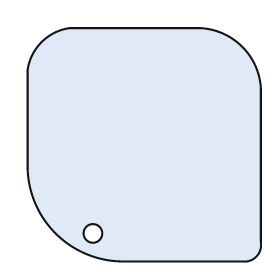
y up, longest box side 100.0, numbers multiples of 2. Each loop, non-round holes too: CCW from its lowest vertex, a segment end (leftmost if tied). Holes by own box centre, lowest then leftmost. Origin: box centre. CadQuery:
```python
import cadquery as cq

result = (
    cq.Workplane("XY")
    .moveTo(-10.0, -50.0)
    .lineTo(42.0, -50.0)
    .threePointArc((48.0, -48.0), (50.0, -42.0))
    .lineTo(50.0, 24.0)
    .threePointArc((42.0, 42.0), (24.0, 50.0))
    .lineTo(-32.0, 50.0)
    .threePointArc((-44.0, 44.0), (-50.0, 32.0))
    .lineTo(-50.0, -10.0)
    .threePointArc((-38.0, -38.0), (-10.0, -50.0))
    .close()
    .moveTo(-22.0, -38.0)
    .circle(4.0)
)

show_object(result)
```